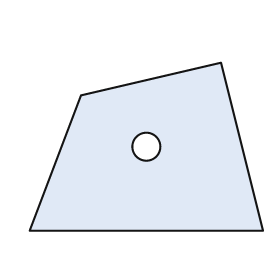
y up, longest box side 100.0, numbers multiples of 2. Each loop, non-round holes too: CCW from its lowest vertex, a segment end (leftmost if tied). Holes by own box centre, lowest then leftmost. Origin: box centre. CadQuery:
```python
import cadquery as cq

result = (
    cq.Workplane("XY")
    .moveTo(-50.0, -36.0)
    .lineTo(50.0, -36.0)
    .lineTo(32.0, 36.0)
    .lineTo(-28.0, 22.0)
    .close()
    .moveTo(0.0, 0.0)
    .circle(6.0)
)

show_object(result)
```